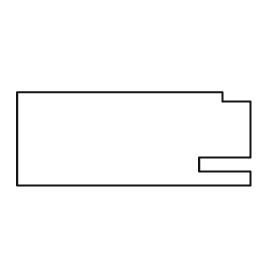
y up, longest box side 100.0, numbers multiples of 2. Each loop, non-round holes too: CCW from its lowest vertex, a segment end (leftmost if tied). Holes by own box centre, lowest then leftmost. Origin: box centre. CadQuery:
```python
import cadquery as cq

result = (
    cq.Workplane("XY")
    .moveTo(-50.0, -20.0)
    .lineTo(50.0, -20.0)
    .lineTo(50.0, -14.0)
    .lineTo(28.0, -14.0)
    .lineTo(28.0, -8.0)
    .lineTo(50.0, -8.0)
    .lineTo(50.0, 16.0)
    .lineTo(38.0, 16.0)
    .lineTo(38.0, 20.0)
    .lineTo(-50.0, 20.0)
    .close()
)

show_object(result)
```